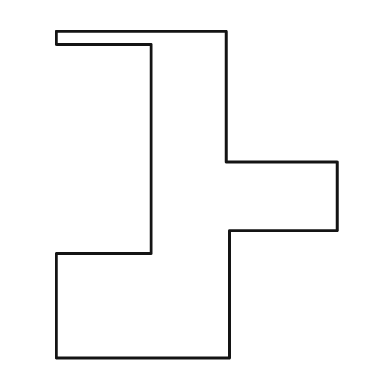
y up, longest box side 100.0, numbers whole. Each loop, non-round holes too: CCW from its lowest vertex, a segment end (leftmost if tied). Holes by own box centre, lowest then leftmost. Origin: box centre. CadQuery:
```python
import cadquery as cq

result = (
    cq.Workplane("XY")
    .moveTo(-43.0, -50.0)
    .lineTo(10.0, -50.0)
    .lineTo(10.0, -11.0)
    .lineTo(43.0, -11.0)
    .lineTo(43.0, 10.0)
    .lineTo(9.0, 10.0)
    .lineTo(9.0, 50.0)
    .lineTo(-43.0, 50.0)
    .lineTo(-43.0, 46.0)
    .lineTo(-14.0, 46.0)
    .lineTo(-14.0, -18.0)
    .lineTo(-43.0, -18.0)
    .close()
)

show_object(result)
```